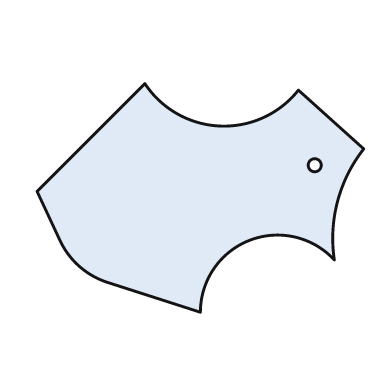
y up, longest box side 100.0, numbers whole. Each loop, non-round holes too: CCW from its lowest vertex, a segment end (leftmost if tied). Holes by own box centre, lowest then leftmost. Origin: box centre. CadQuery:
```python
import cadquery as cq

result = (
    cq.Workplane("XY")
    .moveTo(0.0, -35.0)
    .threePointArc((15.0, -13.0), (41.0, -19.0))
    .threePointArc((42.0, -1.0), (50.0, 15.0))
    .lineTo(30.0, 33.0)
    .threePointArc((6.0, 22.0), (-17.0, 35.0))
    .lineTo(-50.0, 2.0)
    .lineTo(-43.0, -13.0)
    .threePointArc((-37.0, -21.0), (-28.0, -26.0))
    .close()
    .moveTo(35.0, 10.0)
    .circle(2.0)
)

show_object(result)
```